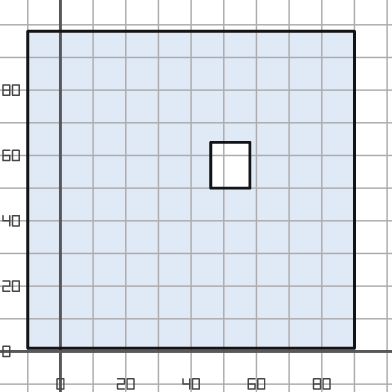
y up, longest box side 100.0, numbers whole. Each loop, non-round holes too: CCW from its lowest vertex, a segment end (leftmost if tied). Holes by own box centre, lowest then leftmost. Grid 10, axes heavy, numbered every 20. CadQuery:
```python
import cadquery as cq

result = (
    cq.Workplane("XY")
    .moveTo(-10.0, 1.0)
    .lineTo(90.0, 1.0)
    .lineTo(90.0, 98.0)
    .lineTo(-10.0, 98.0)
    .close()
    .moveTo(46.0, 50.0)
    .lineTo(58.0, 50.0)
    .lineTo(58.0, 64.0)
    .lineTo(46.0, 64.0)
    .close()
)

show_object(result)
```